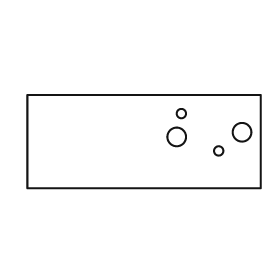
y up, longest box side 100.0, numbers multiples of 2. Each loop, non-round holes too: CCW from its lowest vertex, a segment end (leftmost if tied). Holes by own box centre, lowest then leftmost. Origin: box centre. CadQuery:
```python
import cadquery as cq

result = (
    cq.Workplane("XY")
    .moveTo(-50.0, -20.0)
    .lineTo(50.0, -20.0)
    .lineTo(50.0, 20.0)
    .lineTo(-50.0, 20.0)
    .close()
    .moveTo(32.0, -4.0)
    .circle(2.0)
    .moveTo(14.0, 2.0)
    .circle(4.0)
    .moveTo(42.0, 4.0)
    .circle(4.0)
    .moveTo(16.0, 12.0)
    .circle(2.0)
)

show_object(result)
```